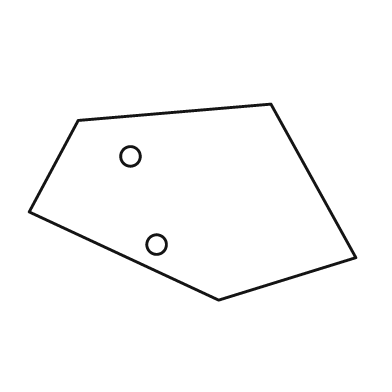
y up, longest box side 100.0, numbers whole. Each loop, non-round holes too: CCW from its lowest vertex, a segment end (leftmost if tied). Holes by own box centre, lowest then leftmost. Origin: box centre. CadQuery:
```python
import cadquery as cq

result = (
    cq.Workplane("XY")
    .moveTo(8.0, -30.0)
    .lineTo(50.0, -17.0)
    .lineTo(24.0, 30.0)
    .lineTo(-35.0, 25.0)
    .lineTo(-50.0, -3.0)
    .close()
    .moveTo(-11.0, -13.0)
    .circle(3.0)
    .moveTo(-19.0, 14.0)
    .circle(3.0)
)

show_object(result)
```